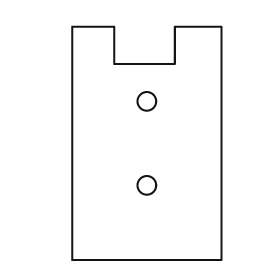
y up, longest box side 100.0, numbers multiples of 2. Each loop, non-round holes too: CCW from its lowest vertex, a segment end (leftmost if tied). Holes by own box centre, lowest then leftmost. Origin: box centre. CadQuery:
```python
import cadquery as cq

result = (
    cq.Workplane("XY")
    .moveTo(-32.0, -50.0)
    .lineTo(32.0, -50.0)
    .lineTo(32.0, 50.0)
    .lineTo(12.0, 50.0)
    .lineTo(12.0, 34.0)
    .lineTo(-14.0, 34.0)
    .lineTo(-14.0, 50.0)
    .lineTo(-32.0, 50.0)
    .close()
    .moveTo(0.0, -18.0)
    .circle(4.0)
    .moveTo(0.0, 18.0)
    .circle(4.0)
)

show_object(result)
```